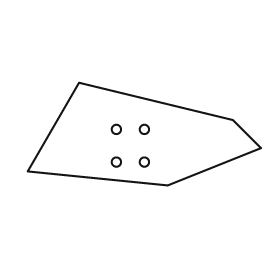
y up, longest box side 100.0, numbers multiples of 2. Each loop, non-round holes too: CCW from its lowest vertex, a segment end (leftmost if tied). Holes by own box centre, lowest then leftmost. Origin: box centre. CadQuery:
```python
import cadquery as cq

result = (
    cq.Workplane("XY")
    .moveTo(10.0, -22.0)
    .lineTo(50.0, -6.0)
    .lineTo(38.0, 6.0)
    .lineTo(-28.0, 22.0)
    .lineTo(-50.0, -16.0)
    .close()
    .moveTo(-12.0, -12.0)
    .circle(2.0)
    .moveTo(0.0, -12.0)
    .circle(2.0)
    .moveTo(-12.0, 2.0)
    .circle(2.0)
    .moveTo(0.0, 2.0)
    .circle(2.0)
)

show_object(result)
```